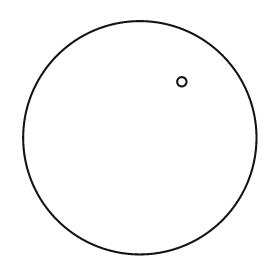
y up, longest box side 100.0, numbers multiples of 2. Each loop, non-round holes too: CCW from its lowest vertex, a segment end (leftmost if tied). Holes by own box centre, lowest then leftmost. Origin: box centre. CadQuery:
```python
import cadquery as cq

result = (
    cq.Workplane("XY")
    .moveTo(0.0, 0.0)
    .circle(50.0)
    .moveTo(18.0, 24.0)
    .circle(2.0)
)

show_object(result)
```